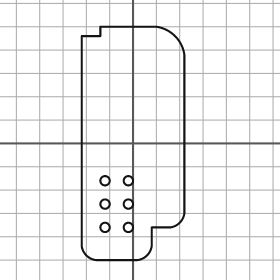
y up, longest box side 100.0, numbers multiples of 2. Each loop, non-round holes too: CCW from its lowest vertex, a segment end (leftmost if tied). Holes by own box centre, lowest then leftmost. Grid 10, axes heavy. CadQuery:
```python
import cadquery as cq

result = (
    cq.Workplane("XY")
    .moveTo(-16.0, -50.0)
    .lineTo(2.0, -50.0)
    .threePointArc((6.0, -48.0), (8.0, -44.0))
    .lineTo(8.0, -36.0)
    .lineTo(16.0, -36.0)
    .threePointArc((20.0, -34.0), (22.0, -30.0))
    .lineTo(22.0, 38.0)
    .threePointArc((18.0, 46.0), (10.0, 50.0))
    .lineTo(-14.0, 50.0)
    .lineTo(-14.0, 46.0)
    .lineTo(-22.0, 46.0)
    .lineTo(-22.0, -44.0)
    .threePointArc((-20.0, -48.0), (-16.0, -50.0))
    .close()
    .moveTo(-12.0, -36.0)
    .circle(2.0)
    .moveTo(-2.0, -36.0)
    .circle(2.0)
    .moveTo(-12.0, -26.0)
    .circle(2.0)
    .moveTo(-2.0, -26.0)
    .circle(2.0)
    .moveTo(-12.0, -16.0)
    .circle(2.0)
    .moveTo(-2.0, -16.0)
    .circle(2.0)
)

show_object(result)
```